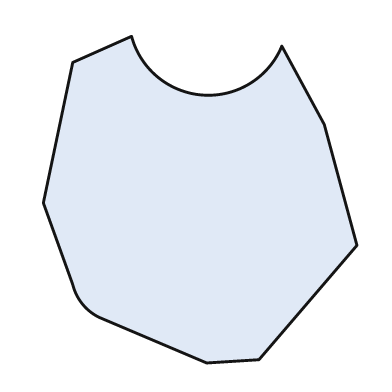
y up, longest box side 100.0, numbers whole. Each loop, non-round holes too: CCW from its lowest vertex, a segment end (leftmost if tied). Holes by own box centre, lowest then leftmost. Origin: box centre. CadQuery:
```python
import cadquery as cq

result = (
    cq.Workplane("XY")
    .moveTo(2.0, -50.0)
    .lineTo(18.0, -49.0)
    .lineTo(48.0, -14.0)
    .lineTo(38.0, 23.0)
    .lineTo(25.0, 47.0)
    .threePointArc((1.0, 32.0), (-21.0, 50.0))
    .lineTo(-39.0, 42.0)
    .lineTo(-48.0, -1.0)
    .lineTo(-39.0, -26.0)
    .threePointArc((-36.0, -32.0), (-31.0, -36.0))
    .close()
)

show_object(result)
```